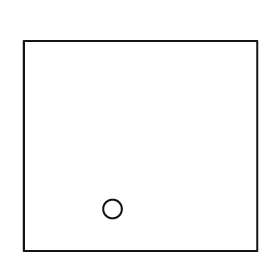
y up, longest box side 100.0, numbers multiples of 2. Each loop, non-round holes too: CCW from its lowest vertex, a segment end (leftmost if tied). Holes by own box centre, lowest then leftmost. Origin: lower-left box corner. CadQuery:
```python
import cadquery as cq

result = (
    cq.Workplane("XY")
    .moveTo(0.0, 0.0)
    .lineTo(100.0, 0.0)
    .lineTo(100.0, 90.0)
    .lineTo(0.0, 90.0)
    .close()
    .moveTo(38.0, 18.0)
    .circle(4.0)
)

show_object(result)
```